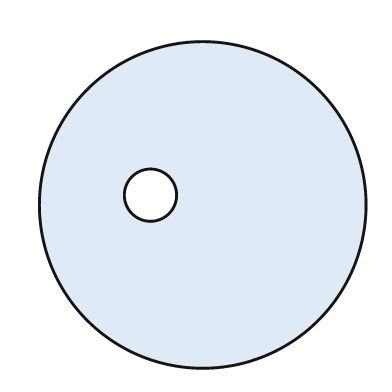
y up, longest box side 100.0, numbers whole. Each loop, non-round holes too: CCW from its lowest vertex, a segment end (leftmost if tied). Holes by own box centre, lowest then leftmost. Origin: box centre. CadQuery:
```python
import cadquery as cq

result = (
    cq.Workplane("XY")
    .moveTo(0.0, 0.0)
    .circle(50.0)
    .moveTo(-16.0, 3.0)
    .circle(8.0)
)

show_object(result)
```